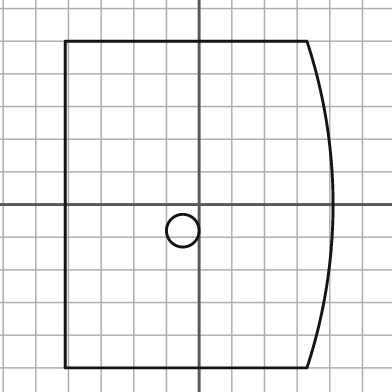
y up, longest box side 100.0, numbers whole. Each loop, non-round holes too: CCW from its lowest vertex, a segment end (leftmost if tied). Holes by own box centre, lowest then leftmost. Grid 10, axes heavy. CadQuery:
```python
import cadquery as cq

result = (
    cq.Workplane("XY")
    .moveTo(-41.0, -50.0)
    .lineTo(33.0, -50.0)
    .threePointArc((41.0, 0.0), (33.0, 50.0))
    .lineTo(-41.0, 50.0)
    .close()
    .moveTo(-5.0, -8.0)
    .circle(5.0)
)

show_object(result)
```